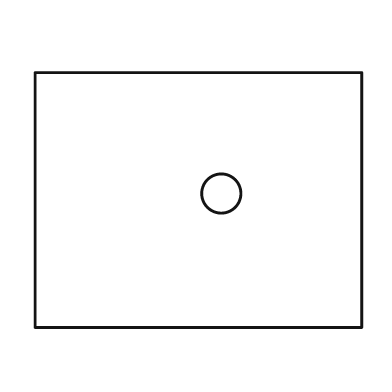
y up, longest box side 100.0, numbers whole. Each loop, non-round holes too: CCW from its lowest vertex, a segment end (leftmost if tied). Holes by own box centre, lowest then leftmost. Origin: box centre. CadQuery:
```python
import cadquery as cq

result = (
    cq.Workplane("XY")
    .moveTo(-50.0, -39.0)
    .lineTo(50.0, -39.0)
    .lineTo(50.0, 39.0)
    .lineTo(-50.0, 39.0)
    .close()
    .moveTo(7.0, 2.0)
    .circle(6.0)
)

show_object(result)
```